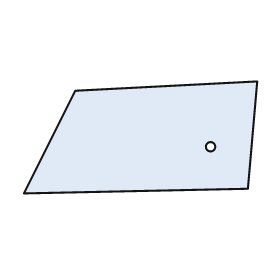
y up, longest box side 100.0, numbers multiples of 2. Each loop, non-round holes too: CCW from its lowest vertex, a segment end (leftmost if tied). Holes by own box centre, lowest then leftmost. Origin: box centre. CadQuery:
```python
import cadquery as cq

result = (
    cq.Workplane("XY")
    .moveTo(-50.0, -24.0)
    .lineTo(46.0, -22.0)
    .lineTo(50.0, 24.0)
    .lineTo(-28.0, 20.0)
    .close()
    .moveTo(30.0, -4.0)
    .circle(2.0)
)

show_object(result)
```